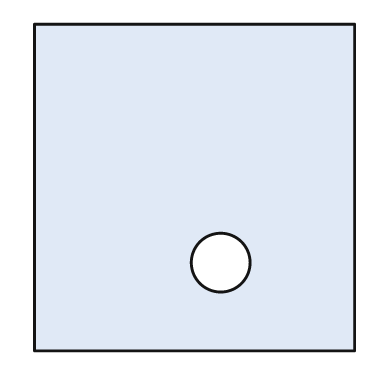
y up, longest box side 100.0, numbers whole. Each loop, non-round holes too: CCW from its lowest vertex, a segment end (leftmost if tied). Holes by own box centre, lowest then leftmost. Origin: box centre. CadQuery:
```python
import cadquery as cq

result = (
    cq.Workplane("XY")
    .moveTo(-49.0, -50.0)
    .lineTo(49.0, -50.0)
    .lineTo(49.0, 50.0)
    .lineTo(-49.0, 50.0)
    .close()
    .moveTo(8.0, -23.0)
    .circle(9.0)
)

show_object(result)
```